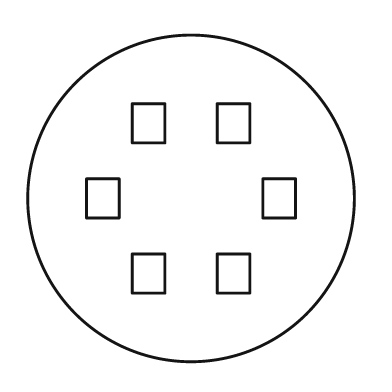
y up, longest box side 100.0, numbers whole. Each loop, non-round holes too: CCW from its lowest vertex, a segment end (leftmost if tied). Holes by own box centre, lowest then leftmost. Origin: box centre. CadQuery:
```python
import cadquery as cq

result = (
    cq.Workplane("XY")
    .moveTo(0.0, 0.0)
    .circle(50.0)
    .moveTo(-18.0, -29.0)
    .lineTo(-8.0, -29.0)
    .lineTo(-8.0, -17.0)
    .lineTo(-18.0, -17.0)
    .close()
    .moveTo(8.0, -29.0)
    .lineTo(18.0, -29.0)
    .lineTo(18.0, -17.0)
    .lineTo(8.0, -17.0)
    .close()
    .moveTo(-32.0, -6.0)
    .lineTo(-22.0, -6.0)
    .lineTo(-22.0, 6.0)
    .lineTo(-32.0, 6.0)
    .close()
    .moveTo(22.0, -6.0)
    .lineTo(32.0, -6.0)
    .lineTo(32.0, 6.0)
    .lineTo(22.0, 6.0)
    .close()
    .moveTo(-18.0, 17.0)
    .lineTo(-8.0, 17.0)
    .lineTo(-8.0, 29.0)
    .lineTo(-18.0, 29.0)
    .close()
    .moveTo(8.0, 17.0)
    .lineTo(18.0, 17.0)
    .lineTo(18.0, 29.0)
    .lineTo(8.0, 29.0)
    .close()
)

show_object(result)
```